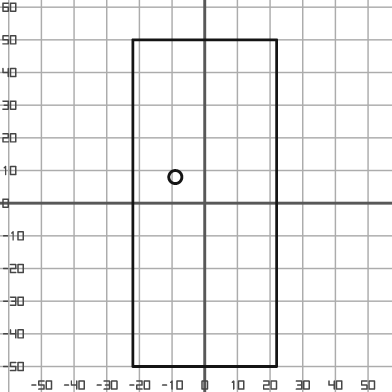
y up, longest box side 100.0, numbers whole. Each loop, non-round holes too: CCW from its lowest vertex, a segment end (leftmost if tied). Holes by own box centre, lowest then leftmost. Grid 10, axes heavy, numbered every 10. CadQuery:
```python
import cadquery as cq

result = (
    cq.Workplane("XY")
    .moveTo(-22.0, -50.0)
    .lineTo(22.0, -50.0)
    .lineTo(22.0, 50.0)
    .lineTo(-22.0, 50.0)
    .close()
    .moveTo(-9.0, 8.0)
    .circle(2.0)
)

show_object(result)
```